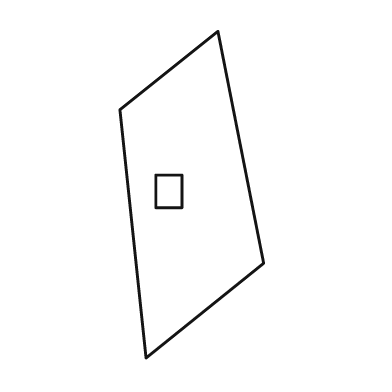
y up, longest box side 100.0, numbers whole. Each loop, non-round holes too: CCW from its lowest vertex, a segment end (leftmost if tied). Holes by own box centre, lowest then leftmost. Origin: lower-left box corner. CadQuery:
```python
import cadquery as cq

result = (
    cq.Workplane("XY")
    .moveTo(8.0, 0.0)
    .lineTo(44.0, 29.0)
    .lineTo(30.0, 100.0)
    .lineTo(0.0, 76.0)
    .close()
    .moveTo(11.0, 46.0)
    .lineTo(19.0, 46.0)
    .lineTo(19.0, 56.0)
    .lineTo(11.0, 56.0)
    .close()
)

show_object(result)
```